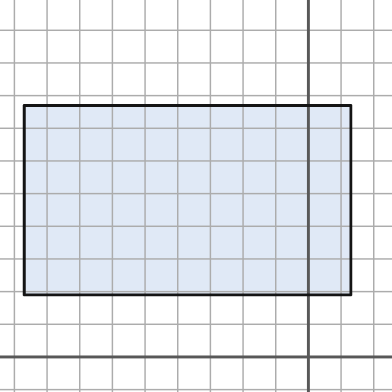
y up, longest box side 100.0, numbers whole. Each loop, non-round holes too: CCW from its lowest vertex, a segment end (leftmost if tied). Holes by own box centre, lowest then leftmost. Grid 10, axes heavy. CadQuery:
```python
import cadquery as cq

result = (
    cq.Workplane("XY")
    .moveTo(-87.0, 19.0)
    .lineTo(13.0, 19.0)
    .lineTo(13.0, 77.0)
    .lineTo(-87.0, 77.0)
    .close()
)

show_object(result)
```